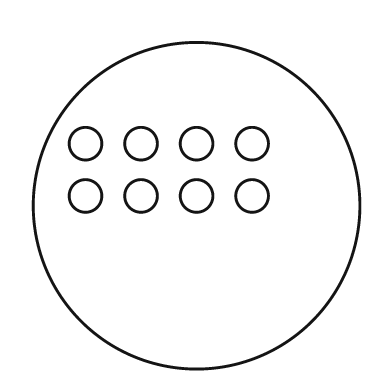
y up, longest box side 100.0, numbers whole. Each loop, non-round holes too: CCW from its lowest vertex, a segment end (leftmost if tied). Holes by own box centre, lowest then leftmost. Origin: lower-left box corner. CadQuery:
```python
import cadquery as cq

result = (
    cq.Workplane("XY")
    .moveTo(50.0, 50.0)
    .circle(50.0)
    .moveTo(16.0, 53.0)
    .circle(5.0)
    .moveTo(33.0, 53.0)
    .circle(5.0)
    .moveTo(50.0, 53.0)
    .circle(5.0)
    .moveTo(67.0, 53.0)
    .circle(5.0)
    .moveTo(16.0, 69.0)
    .circle(5.0)
    .moveTo(33.0, 69.0)
    .circle(5.0)
    .moveTo(50.0, 69.0)
    .circle(5.0)
    .moveTo(67.0, 69.0)
    .circle(5.0)
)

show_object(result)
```